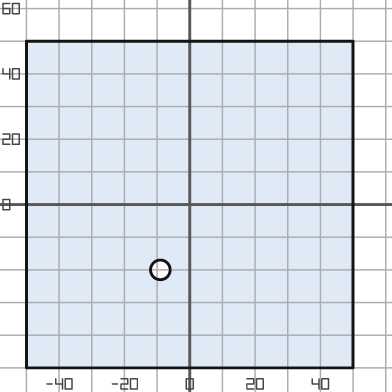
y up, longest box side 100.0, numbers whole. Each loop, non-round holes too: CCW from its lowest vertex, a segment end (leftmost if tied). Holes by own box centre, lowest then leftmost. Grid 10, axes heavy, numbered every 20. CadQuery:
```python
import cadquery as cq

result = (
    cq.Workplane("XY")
    .moveTo(-50.0, -50.0)
    .lineTo(50.0, -50.0)
    .lineTo(50.0, 50.0)
    .lineTo(-50.0, 50.0)
    .close()
    .moveTo(-9.0, -20.0)
    .circle(3.0)
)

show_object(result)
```